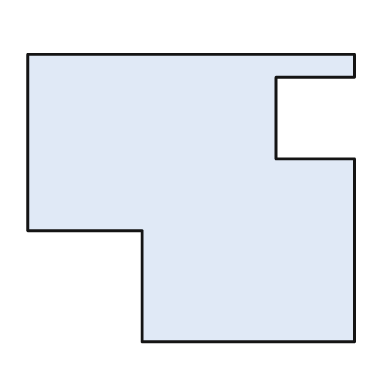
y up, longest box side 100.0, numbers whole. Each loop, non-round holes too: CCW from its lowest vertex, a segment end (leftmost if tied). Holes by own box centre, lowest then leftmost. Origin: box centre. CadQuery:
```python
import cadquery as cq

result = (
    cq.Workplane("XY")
    .moveTo(-15.0, -44.0)
    .lineTo(50.0, -44.0)
    .lineTo(50.0, 12.0)
    .lineTo(26.0, 12.0)
    .lineTo(26.0, 37.0)
    .lineTo(50.0, 37.0)
    .lineTo(50.0, 44.0)
    .lineTo(-50.0, 44.0)
    .lineTo(-50.0, -10.0)
    .lineTo(-15.0, -10.0)
    .close()
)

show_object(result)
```